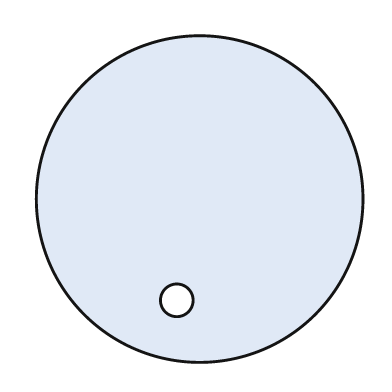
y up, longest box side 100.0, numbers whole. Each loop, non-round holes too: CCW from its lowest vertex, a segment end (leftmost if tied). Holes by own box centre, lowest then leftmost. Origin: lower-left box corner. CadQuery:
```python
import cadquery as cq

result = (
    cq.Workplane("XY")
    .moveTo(50.0, 50.0)
    .circle(50.0)
    .moveTo(43.0, 19.0)
    .circle(5.0)
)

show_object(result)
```